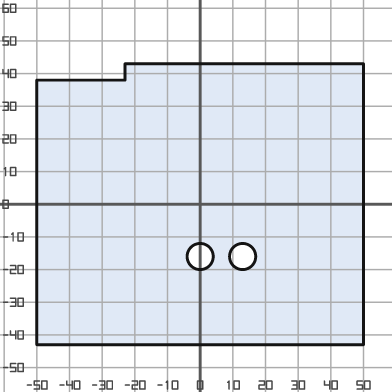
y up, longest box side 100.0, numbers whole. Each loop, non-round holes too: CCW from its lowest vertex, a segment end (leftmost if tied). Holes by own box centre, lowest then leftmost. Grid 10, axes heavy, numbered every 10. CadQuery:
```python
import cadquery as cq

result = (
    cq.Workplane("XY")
    .moveTo(-50.0, -43.0)
    .lineTo(50.0, -43.0)
    .lineTo(50.0, 43.0)
    .lineTo(-23.0, 43.0)
    .lineTo(-23.0, 38.0)
    .lineTo(-50.0, 38.0)
    .close()
    .moveTo(0.0, -16.0)
    .circle(4.0)
    .moveTo(13.0, -16.0)
    .circle(4.0)
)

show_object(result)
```